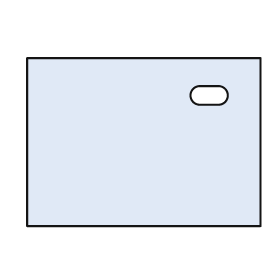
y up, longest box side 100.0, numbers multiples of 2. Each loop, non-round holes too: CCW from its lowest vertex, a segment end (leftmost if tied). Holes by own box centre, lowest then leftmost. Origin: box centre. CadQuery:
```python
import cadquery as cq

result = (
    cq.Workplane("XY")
    .moveTo(-50.0, -36.0)
    .lineTo(50.0, -36.0)
    .lineTo(50.0, 36.0)
    .lineTo(-50.0, 36.0)
    .close()
    .moveTo(24.0, 16.0)
    .lineTo(32.0, 16.0)
    .threePointArc((36.0, 20.0), (32.0, 24.0))
    .lineTo(24.0, 24.0)
    .threePointArc((20.0, 20.0), (24.0, 16.0))
    .close()
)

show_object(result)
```